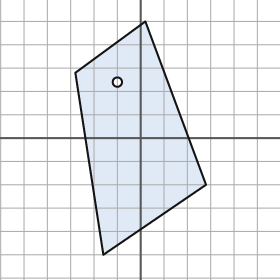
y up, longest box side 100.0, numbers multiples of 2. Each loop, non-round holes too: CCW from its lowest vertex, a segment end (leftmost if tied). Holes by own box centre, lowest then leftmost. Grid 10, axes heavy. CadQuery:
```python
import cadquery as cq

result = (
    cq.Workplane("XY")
    .moveTo(-16.0, -50.0)
    .lineTo(28.0, -20.0)
    .lineTo(2.0, 50.0)
    .lineTo(-28.0, 28.0)
    .close()
    .moveTo(-10.0, 24.0)
    .circle(2.0)
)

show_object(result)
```